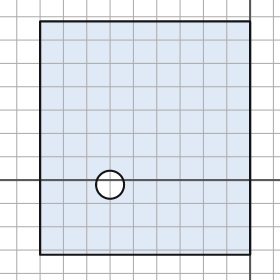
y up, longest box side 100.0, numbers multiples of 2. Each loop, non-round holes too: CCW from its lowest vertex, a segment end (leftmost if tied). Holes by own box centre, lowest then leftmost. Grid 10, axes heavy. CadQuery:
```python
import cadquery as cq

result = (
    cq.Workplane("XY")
    .moveTo(-90.0, -32.0)
    .lineTo(0.0, -32.0)
    .lineTo(0.0, 68.0)
    .lineTo(-90.0, 68.0)
    .close()
    .moveTo(-60.0, -2.0)
    .circle(6.0)
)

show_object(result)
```